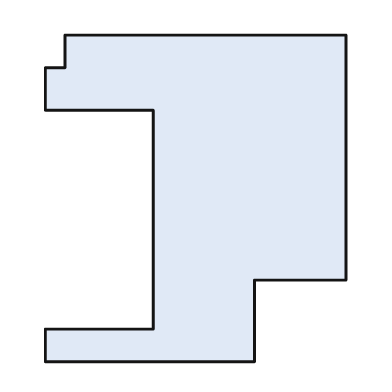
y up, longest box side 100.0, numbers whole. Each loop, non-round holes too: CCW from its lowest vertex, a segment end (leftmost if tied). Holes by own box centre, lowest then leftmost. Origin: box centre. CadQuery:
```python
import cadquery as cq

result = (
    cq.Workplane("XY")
    .moveTo(-46.0, -50.0)
    .lineTo(18.0, -50.0)
    .lineTo(18.0, -25.0)
    .lineTo(46.0, -25.0)
    .lineTo(46.0, 50.0)
    .lineTo(-40.0, 50.0)
    .lineTo(-40.0, 40.0)
    .lineTo(-46.0, 40.0)
    .lineTo(-46.0, 27.0)
    .lineTo(-13.0, 27.0)
    .lineTo(-13.0, -40.0)
    .lineTo(-46.0, -40.0)
    .close()
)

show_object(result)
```